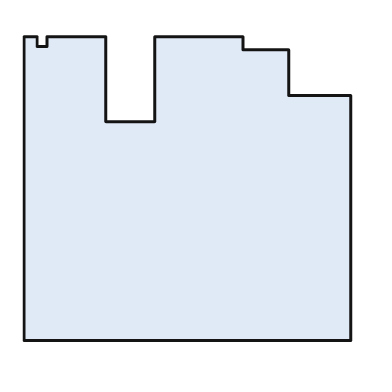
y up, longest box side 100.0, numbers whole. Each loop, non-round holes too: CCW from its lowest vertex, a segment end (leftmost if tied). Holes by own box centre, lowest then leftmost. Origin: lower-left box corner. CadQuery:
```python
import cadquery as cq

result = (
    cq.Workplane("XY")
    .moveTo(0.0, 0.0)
    .lineTo(100.0, 0.0)
    .lineTo(100.0, 75.0)
    .lineTo(81.0, 75.0)
    .lineTo(81.0, 89.0)
    .lineTo(67.0, 89.0)
    .lineTo(67.0, 93.0)
    .lineTo(40.0, 93.0)
    .lineTo(40.0, 67.0)
    .lineTo(25.0, 67.0)
    .lineTo(25.0, 93.0)
    .lineTo(7.0, 93.0)
    .lineTo(7.0, 90.0)
    .lineTo(4.0, 90.0)
    .lineTo(4.0, 93.0)
    .lineTo(0.0, 93.0)
    .close()
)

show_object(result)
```